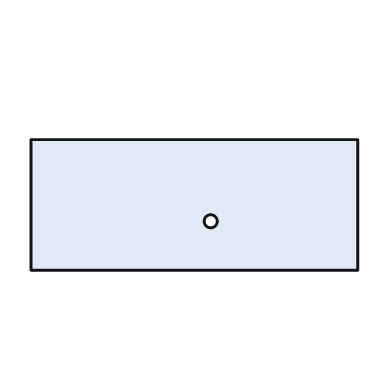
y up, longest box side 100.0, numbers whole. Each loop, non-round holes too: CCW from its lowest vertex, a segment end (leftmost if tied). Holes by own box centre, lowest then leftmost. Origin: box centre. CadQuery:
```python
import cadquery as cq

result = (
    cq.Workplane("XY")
    .moveTo(-50.0, -20.0)
    .lineTo(50.0, -20.0)
    .lineTo(50.0, 20.0)
    .lineTo(-50.0, 20.0)
    .close()
    .moveTo(5.0, -5.0)
    .circle(2.0)
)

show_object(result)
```